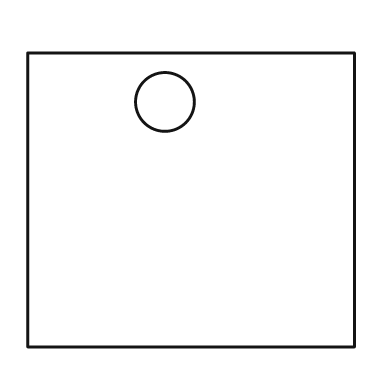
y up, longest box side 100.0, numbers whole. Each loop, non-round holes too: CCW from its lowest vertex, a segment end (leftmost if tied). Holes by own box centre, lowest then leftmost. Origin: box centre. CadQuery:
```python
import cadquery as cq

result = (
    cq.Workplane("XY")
    .moveTo(-50.0, -45.0)
    .lineTo(50.0, -45.0)
    .lineTo(50.0, 45.0)
    .lineTo(-50.0, 45.0)
    .close()
    .moveTo(-8.0, 30.0)
    .circle(9.0)
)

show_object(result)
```